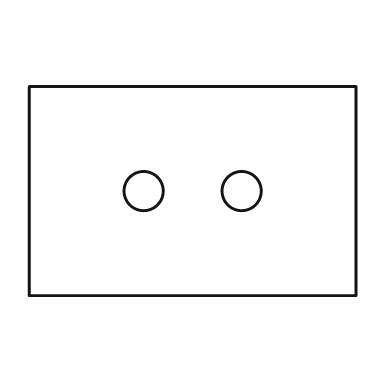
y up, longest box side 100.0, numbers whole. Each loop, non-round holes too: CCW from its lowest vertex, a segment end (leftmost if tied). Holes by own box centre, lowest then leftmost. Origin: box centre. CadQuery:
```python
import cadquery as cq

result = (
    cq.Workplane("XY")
    .moveTo(-50.0, -32.0)
    .lineTo(50.0, -32.0)
    .lineTo(50.0, 32.0)
    .lineTo(-50.0, 32.0)
    .close()
    .moveTo(-15.0, 0.0)
    .circle(6.0)
    .moveTo(15.0, 0.0)
    .circle(6.0)
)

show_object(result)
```